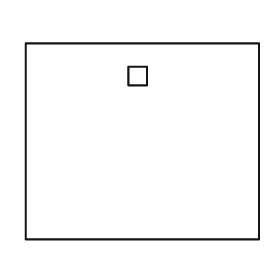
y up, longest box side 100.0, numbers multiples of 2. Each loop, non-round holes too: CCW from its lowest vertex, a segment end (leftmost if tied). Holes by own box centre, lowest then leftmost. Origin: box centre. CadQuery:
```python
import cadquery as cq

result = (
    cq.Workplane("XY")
    .moveTo(-50.0, -42.0)
    .lineTo(50.0, -42.0)
    .lineTo(50.0, 42.0)
    .lineTo(-50.0, 42.0)
    .close()
    .moveTo(-6.0, 24.0)
    .lineTo(2.0, 24.0)
    .lineTo(2.0, 32.0)
    .lineTo(-6.0, 32.0)
    .close()
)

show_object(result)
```